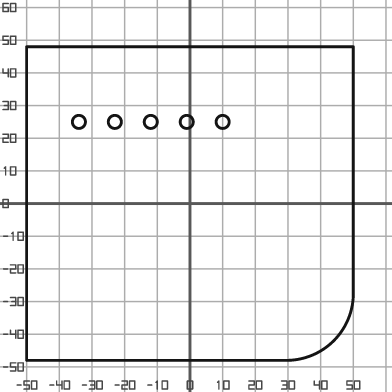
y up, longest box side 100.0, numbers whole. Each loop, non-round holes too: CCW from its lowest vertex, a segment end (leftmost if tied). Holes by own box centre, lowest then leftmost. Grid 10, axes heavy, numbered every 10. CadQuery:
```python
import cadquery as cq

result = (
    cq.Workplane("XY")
    .moveTo(-50.0, -48.0)
    .lineTo(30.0, -48.0)
    .threePointArc((44.0, -42.0), (50.0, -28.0))
    .lineTo(50.0, 48.0)
    .lineTo(-50.0, 48.0)
    .close()
    .moveTo(-34.0, 25.0)
    .circle(2.0)
    .moveTo(-23.0, 25.0)
    .circle(2.0)
    .moveTo(-12.0, 25.0)
    .circle(2.0)
    .moveTo(-1.0, 25.0)
    .circle(2.0)
    .moveTo(10.0, 25.0)
    .circle(2.0)
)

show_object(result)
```